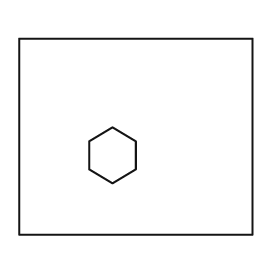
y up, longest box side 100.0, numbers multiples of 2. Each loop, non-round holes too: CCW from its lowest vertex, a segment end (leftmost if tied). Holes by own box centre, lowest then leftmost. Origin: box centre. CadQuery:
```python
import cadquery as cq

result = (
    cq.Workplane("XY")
    .moveTo(-50.0, -42.0)
    .lineTo(50.0, -42.0)
    .lineTo(50.0, 42.0)
    .lineTo(-50.0, 42.0)
    .close()
    .moveTo(-10.0, -20.0)
    .lineTo(0.0, -14.0)
    .lineTo(0.0, -2.0)
    .lineTo(-10.0, 4.0)
    .lineTo(-20.0, -2.0)
    .lineTo(-20.0, -14.0)
    .close()
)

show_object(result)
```